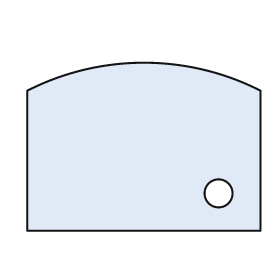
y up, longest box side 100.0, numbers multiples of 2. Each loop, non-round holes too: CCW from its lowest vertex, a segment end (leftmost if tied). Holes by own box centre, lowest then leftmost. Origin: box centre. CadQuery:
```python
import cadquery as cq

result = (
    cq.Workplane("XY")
    .moveTo(-50.0, -36.0)
    .lineTo(50.0, -36.0)
    .lineTo(50.0, 24.0)
    .threePointArc((0.0, 36.0), (-50.0, 24.0))
    .close()
    .moveTo(32.0, -20.0)
    .circle(6.0)
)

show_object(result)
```